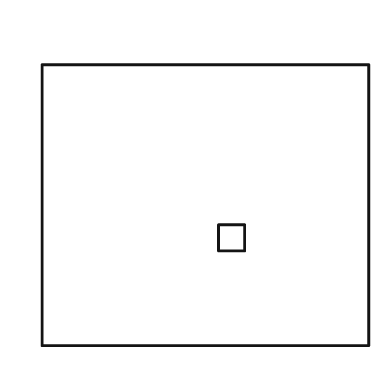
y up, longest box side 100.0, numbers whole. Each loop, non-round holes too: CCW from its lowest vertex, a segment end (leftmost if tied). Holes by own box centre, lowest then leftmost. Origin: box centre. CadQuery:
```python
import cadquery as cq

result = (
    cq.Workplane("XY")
    .moveTo(-50.0, -43.0)
    .lineTo(50.0, -43.0)
    .lineTo(50.0, 43.0)
    .lineTo(-50.0, 43.0)
    .close()
    .moveTo(4.0, -14.0)
    .lineTo(12.0, -14.0)
    .lineTo(12.0, -6.0)
    .lineTo(4.0, -6.0)
    .close()
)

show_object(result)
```